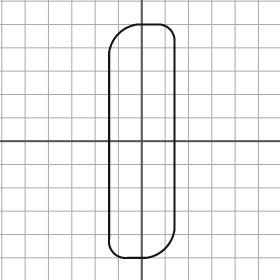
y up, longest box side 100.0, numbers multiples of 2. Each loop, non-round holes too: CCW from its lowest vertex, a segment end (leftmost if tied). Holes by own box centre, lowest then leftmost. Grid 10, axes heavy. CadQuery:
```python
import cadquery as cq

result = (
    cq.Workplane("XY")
    .moveTo(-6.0, -50.0)
    .lineTo(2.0, -50.0)
    .threePointArc((10.0, -46.0), (14.0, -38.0))
    .lineTo(14.0, 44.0)
    .threePointArc((12.0, 48.0), (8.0, 50.0))
    .lineTo(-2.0, 50.0)
    .threePointArc((-10.0, 46.0), (-14.0, 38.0))
    .lineTo(-14.0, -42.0)
    .threePointArc((-12.0, -48.0), (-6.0, -50.0))
    .close()
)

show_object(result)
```